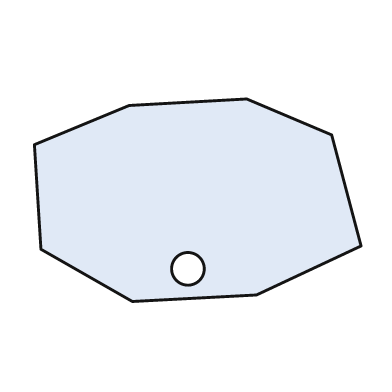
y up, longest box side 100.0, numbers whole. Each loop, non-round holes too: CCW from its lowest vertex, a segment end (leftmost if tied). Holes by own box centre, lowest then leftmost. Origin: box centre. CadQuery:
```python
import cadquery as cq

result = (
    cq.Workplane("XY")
    .moveTo(-20.0, -31.0)
    .lineTo(18.0, -29.0)
    .lineTo(50.0, -14.0)
    .lineTo(41.0, 20.0)
    .lineTo(15.0, 31.0)
    .lineTo(-21.0, 29.0)
    .lineTo(-50.0, 17.0)
    .lineTo(-48.0, -15.0)
    .close()
    .moveTo(-3.0, -21.0)
    .circle(5.0)
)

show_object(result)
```